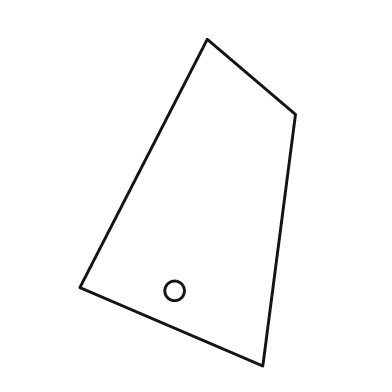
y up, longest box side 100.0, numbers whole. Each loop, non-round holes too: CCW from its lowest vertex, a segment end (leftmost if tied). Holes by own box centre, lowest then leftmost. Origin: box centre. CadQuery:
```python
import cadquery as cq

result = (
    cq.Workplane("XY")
    .moveTo(23.0, -50.0)
    .lineTo(33.0, 27.0)
    .lineTo(6.0, 50.0)
    .lineTo(-33.0, -26.0)
    .close()
    .moveTo(-4.0, -27.0)
    .circle(3.0)
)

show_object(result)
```